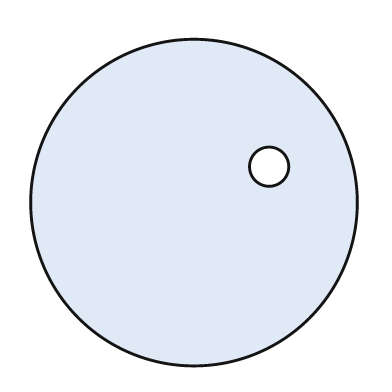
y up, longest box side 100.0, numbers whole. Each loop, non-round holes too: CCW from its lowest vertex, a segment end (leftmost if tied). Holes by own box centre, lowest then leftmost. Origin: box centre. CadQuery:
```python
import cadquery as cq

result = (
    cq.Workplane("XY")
    .moveTo(0.0, 0.0)
    .circle(50.0)
    .moveTo(23.0, 11.0)
    .circle(6.0)
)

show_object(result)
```